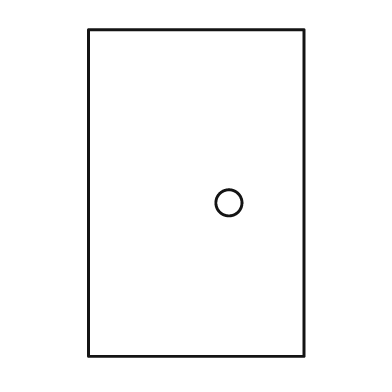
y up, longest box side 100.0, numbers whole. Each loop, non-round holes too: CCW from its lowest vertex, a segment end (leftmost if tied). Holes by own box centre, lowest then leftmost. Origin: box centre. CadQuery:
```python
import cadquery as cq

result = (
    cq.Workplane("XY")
    .moveTo(-33.0, -50.0)
    .lineTo(33.0, -50.0)
    .lineTo(33.0, 50.0)
    .lineTo(-33.0, 50.0)
    .close()
    .moveTo(10.0, -3.0)
    .circle(4.0)
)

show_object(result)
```